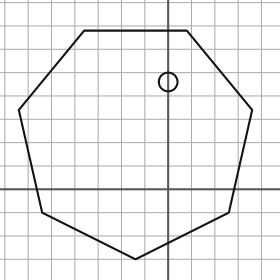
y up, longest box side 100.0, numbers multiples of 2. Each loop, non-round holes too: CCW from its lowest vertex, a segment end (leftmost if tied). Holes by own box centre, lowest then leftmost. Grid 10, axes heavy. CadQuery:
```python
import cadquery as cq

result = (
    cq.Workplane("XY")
    .moveTo(-14.0, -30.0)
    .lineTo(26.0, -10.0)
    .lineTo(36.0, 34.0)
    .lineTo(8.0, 68.0)
    .lineTo(-36.0, 68.0)
    .lineTo(-64.0, 34.0)
    .lineTo(-54.0, -10.0)
    .close()
    .moveTo(0.0, 46.0)
    .circle(4.0)
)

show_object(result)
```